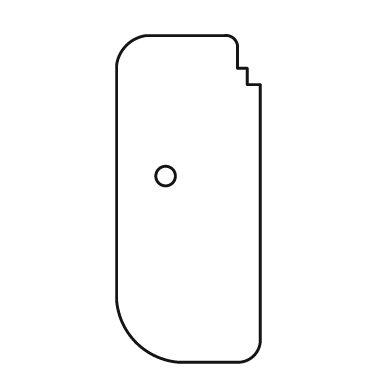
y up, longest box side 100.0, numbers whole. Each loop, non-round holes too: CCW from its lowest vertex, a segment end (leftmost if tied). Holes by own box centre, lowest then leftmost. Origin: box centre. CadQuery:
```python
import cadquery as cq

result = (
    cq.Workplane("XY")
    .moveTo(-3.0, -50.0)
    .lineTo(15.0, -50.0)
    .threePointArc((20.0, -48.0), (22.0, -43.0))
    .lineTo(22.0, 35.0)
    .lineTo(18.0, 35.0)
    .lineTo(18.0, 40.0)
    .lineTo(15.0, 40.0)
    .lineTo(15.0, 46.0)
    .threePointArc((14.0, 49.0), (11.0, 50.0))
    .lineTo(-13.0, 50.0)
    .threePointArc((-19.0, 47.0), (-22.0, 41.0))
    .lineTo(-22.0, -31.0)
    .threePointArc((-16.0, -44.0), (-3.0, -50.0))
    .close()
    .moveTo(-7.0, 7.0)
    .circle(3.0)
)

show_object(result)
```